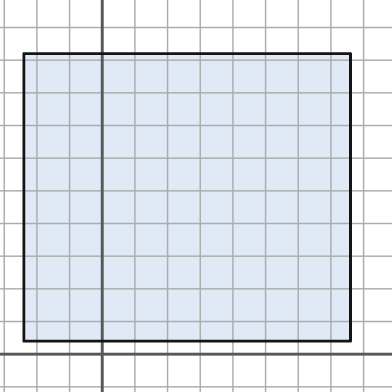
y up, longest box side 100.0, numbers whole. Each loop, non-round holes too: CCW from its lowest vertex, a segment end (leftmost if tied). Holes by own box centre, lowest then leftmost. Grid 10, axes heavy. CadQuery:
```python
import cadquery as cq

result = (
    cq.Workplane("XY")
    .moveTo(-24.0, 4.0)
    .lineTo(76.0, 4.0)
    .lineTo(76.0, 92.0)
    .lineTo(-24.0, 92.0)
    .close()
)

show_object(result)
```